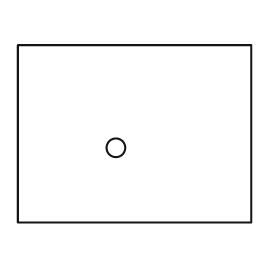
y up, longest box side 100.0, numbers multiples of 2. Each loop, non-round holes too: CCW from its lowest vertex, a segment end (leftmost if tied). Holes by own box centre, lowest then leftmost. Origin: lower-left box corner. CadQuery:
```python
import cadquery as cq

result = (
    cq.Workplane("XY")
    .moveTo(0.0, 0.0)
    .lineTo(100.0, 0.0)
    .lineTo(100.0, 76.0)
    .lineTo(0.0, 76.0)
    .close()
    .moveTo(42.0, 32.0)
    .circle(4.0)
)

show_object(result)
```